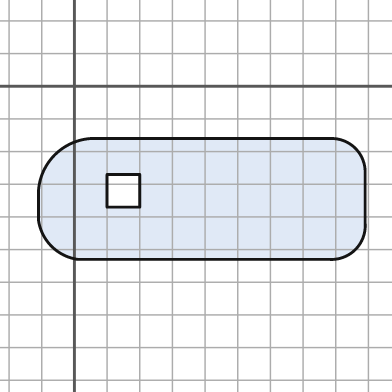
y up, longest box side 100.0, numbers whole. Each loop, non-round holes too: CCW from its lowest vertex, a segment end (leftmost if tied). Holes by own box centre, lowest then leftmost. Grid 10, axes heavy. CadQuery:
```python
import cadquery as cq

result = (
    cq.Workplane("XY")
    .moveTo(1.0, -53.0)
    .lineTo(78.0, -53.0)
    .threePointArc((86.0, -50.0), (89.0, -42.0))
    .lineTo(89.0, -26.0)
    .threePointArc((86.0, -19.0), (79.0, -16.0))
    .lineTo(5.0, -16.0)
    .threePointArc((-6.0, -21.0), (-11.0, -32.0))
    .lineTo(-11.0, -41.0)
    .threePointArc((-7.0, -49.0), (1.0, -53.0))
    .close()
    .moveTo(10.0, -37.0)
    .lineTo(20.0, -37.0)
    .lineTo(20.0, -27.0)
    .lineTo(10.0, -27.0)
    .close()
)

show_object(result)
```